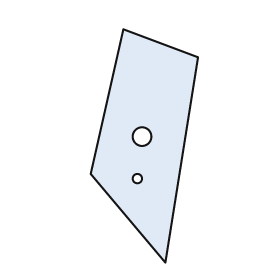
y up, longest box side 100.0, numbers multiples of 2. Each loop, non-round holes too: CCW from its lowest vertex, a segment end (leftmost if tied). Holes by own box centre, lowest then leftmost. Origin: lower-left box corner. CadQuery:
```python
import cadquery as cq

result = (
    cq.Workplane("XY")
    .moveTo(32.0, 0.0)
    .lineTo(46.0, 88.0)
    .lineTo(14.0, 100.0)
    .lineTo(0.0, 38.0)
    .close()
    .moveTo(20.0, 36.0)
    .circle(2.0)
    .moveTo(22.0, 54.0)
    .circle(4.0)
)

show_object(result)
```